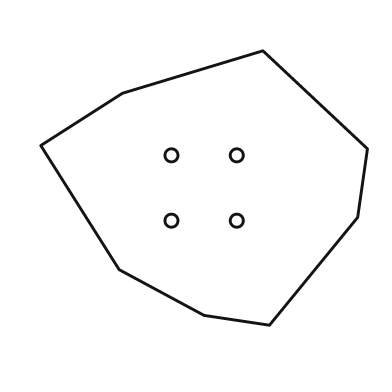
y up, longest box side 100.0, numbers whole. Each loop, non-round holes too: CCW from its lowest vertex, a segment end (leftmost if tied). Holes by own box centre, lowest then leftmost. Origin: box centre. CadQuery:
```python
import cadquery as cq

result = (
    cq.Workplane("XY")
    .moveTo(20.0, -42.0)
    .lineTo(47.0, -9.0)
    .lineTo(50.0, 12.0)
    .lineTo(18.0, 42.0)
    .lineTo(-25.0, 29.0)
    .lineTo(-50.0, 13.0)
    .lineTo(-26.0, -25.0)
    .lineTo(0.0, -39.0)
    .close()
    .moveTo(-10.0, -10.0)
    .circle(2.0)
    .moveTo(10.0, -10.0)
    .circle(2.0)
    .moveTo(-10.0, 10.0)
    .circle(2.0)
    .moveTo(10.0, 10.0)
    .circle(2.0)
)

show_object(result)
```